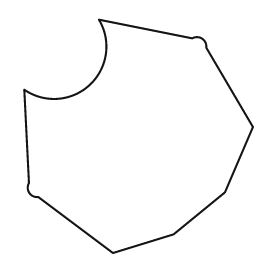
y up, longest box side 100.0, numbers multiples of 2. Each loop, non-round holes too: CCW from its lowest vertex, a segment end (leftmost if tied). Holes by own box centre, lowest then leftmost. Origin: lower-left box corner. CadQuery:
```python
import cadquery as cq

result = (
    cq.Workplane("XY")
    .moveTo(38.0, 0.0)
    .lineTo(64.0, 8.0)
    .lineTo(86.0, 26.0)
    .lineTo(98.0, 54.0)
    .lineTo(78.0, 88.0)
    .threePointArc((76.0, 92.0), (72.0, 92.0))
    .lineTo(32.0, 100.0)
    .threePointArc((28.0, 72.0), (0.0, 70.0))
    .lineTo(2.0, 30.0)
    .threePointArc((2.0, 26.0), (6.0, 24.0))
    .close()
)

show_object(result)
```